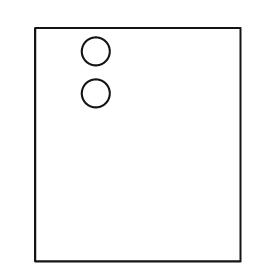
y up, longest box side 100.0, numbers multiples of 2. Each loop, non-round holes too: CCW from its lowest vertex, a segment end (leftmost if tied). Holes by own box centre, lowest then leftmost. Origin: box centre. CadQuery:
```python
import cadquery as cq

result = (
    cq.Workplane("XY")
    .moveTo(-44.0, -50.0)
    .lineTo(44.0, -50.0)
    .lineTo(44.0, 50.0)
    .lineTo(-44.0, 50.0)
    .close()
    .moveTo(-18.0, 22.0)
    .circle(6.0)
    .moveTo(-18.0, 40.0)
    .circle(6.0)
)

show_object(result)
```